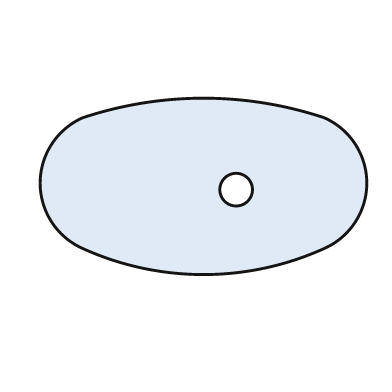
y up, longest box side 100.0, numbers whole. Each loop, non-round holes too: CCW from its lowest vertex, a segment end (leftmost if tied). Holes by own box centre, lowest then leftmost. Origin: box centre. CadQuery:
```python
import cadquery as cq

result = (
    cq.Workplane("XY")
    .moveTo(-37.0, -19.0)
    .threePointArc((0.0, -27.0), (37.0, -19.0))
    .threePointArc((50.0, 1.0), (37.0, 21.0))
    .threePointArc((0.0, 27.0), (-37.0, 21.0))
    .threePointArc((-50.0, 1.0), (-37.0, -19.0))
    .close()
    .moveTo(10.0, -1.0)
    .circle(5.0)
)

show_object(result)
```